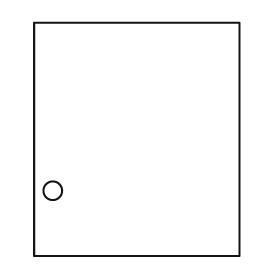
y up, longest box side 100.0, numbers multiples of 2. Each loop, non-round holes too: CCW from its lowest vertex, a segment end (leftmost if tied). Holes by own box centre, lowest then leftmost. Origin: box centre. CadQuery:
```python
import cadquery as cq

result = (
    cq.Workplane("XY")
    .moveTo(-44.0, -50.0)
    .lineTo(44.0, -50.0)
    .lineTo(44.0, 50.0)
    .lineTo(-44.0, 50.0)
    .close()
    .moveTo(-36.0, -22.0)
    .circle(4.0)
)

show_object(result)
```